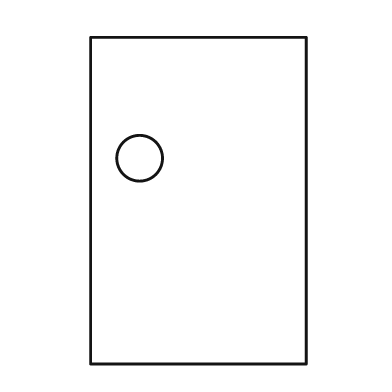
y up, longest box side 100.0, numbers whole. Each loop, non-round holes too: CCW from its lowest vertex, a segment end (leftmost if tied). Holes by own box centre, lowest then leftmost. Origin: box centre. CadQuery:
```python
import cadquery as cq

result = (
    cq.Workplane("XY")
    .moveTo(-33.0, -50.0)
    .lineTo(33.0, -50.0)
    .lineTo(33.0, 50.0)
    .lineTo(-33.0, 50.0)
    .close()
    .moveTo(-18.0, 13.0)
    .circle(7.0)
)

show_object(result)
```